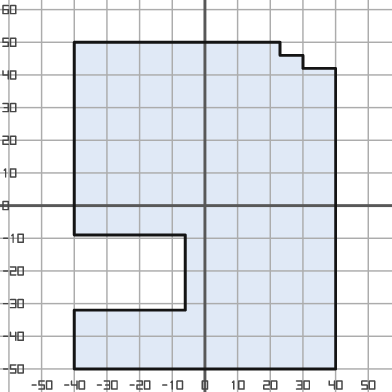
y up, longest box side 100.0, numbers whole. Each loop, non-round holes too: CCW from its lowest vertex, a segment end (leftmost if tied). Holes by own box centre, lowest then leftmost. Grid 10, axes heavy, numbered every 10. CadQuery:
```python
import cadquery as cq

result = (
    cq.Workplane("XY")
    .moveTo(-40.0, -50.0)
    .lineTo(40.0, -50.0)
    .lineTo(40.0, 42.0)
    .lineTo(30.0, 42.0)
    .lineTo(30.0, 46.0)
    .lineTo(23.0, 46.0)
    .lineTo(23.0, 50.0)
    .lineTo(-40.0, 50.0)
    .lineTo(-40.0, -9.0)
    .lineTo(-6.0, -9.0)
    .lineTo(-6.0, -32.0)
    .lineTo(-40.0, -32.0)
    .close()
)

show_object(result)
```